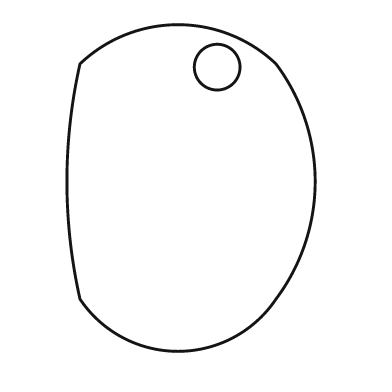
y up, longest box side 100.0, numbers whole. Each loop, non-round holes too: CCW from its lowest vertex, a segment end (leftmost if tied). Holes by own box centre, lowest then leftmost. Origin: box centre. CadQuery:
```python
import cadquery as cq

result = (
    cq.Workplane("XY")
    .moveTo(-34.0, -34.0)
    .threePointArc((-4.0, -50.0), (26.0, -34.0))
    .threePointArc((38.0, 2.0), (26.0, 38.0))
    .threePointArc((-4.0, 50.0), (-34.0, 38.0))
    .threePointArc((-38.0, 2.0), (-34.0, -34.0))
    .close()
    .moveTo(8.0, 37.0)
    .circle(7.0)
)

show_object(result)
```